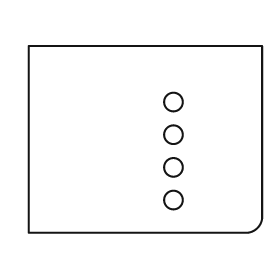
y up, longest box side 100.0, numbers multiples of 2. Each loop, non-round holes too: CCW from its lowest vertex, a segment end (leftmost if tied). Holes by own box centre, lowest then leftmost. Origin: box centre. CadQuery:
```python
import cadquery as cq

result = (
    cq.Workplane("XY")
    .moveTo(-50.0, -40.0)
    .lineTo(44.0, -40.0)
    .threePointArc((48.0, -38.0), (50.0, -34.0))
    .lineTo(50.0, 40.0)
    .lineTo(-50.0, 40.0)
    .close()
    .moveTo(12.0, -26.0)
    .circle(4.0)
    .moveTo(12.0, -12.0)
    .circle(4.0)
    .moveTo(12.0, 2.0)
    .circle(4.0)
    .moveTo(12.0, 16.0)
    .circle(4.0)
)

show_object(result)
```